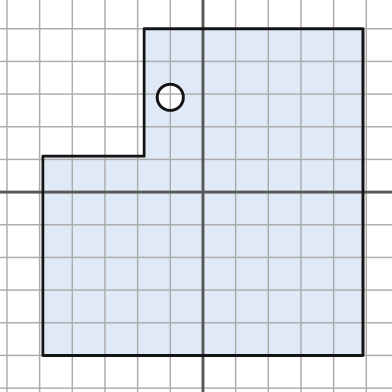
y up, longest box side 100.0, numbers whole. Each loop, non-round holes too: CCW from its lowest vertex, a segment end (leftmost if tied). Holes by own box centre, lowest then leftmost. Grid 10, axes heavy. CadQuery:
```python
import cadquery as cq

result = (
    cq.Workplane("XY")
    .moveTo(-49.0, -50.0)
    .lineTo(49.0, -50.0)
    .lineTo(49.0, 50.0)
    .lineTo(-18.0, 50.0)
    .lineTo(-18.0, 11.0)
    .lineTo(-49.0, 11.0)
    .close()
    .moveTo(-10.0, 29.0)
    .circle(4.0)
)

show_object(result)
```